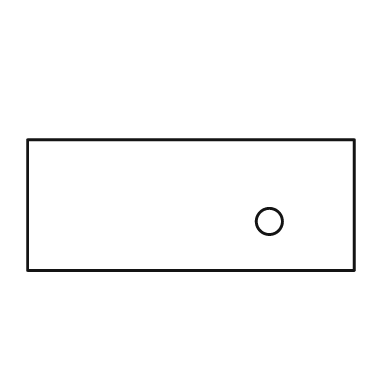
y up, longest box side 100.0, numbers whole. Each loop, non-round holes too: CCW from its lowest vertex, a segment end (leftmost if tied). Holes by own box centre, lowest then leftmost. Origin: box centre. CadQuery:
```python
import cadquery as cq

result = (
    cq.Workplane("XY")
    .moveTo(-50.0, -20.0)
    .lineTo(50.0, -20.0)
    .lineTo(50.0, 20.0)
    .lineTo(-50.0, 20.0)
    .close()
    .moveTo(24.0, -5.0)
    .circle(4.0)
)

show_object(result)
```